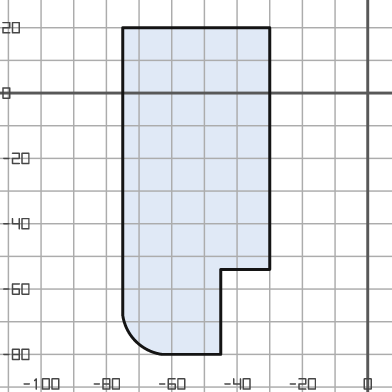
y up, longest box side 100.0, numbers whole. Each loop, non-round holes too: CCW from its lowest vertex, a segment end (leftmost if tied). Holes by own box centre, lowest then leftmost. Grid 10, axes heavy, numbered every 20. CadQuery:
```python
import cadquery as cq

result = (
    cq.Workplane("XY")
    .moveTo(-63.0, -80.0)
    .lineTo(-45.0, -80.0)
    .lineTo(-45.0, -54.0)
    .lineTo(-30.0, -54.0)
    .lineTo(-30.0, 20.0)
    .lineTo(-75.0, 20.0)
    .lineTo(-75.0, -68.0)
    .threePointArc((-71.0, -76.0), (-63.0, -80.0))
    .close()
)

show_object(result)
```